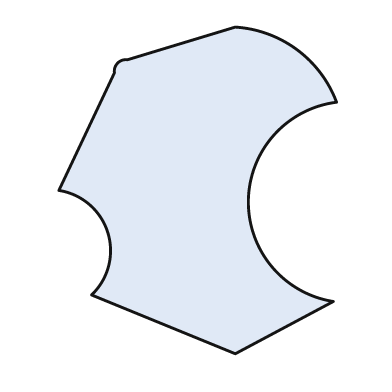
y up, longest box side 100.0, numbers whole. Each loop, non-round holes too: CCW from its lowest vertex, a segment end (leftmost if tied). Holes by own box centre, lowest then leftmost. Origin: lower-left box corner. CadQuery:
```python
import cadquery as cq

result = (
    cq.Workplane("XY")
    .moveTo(54.0, 0.0)
    .lineTo(84.0, 16.0)
    .threePointArc((58.0, 47.0), (85.0, 77.0))
    .threePointArc((73.0, 93.0), (54.0, 100.0))
    .lineTo(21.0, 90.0)
    .threePointArc((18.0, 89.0), (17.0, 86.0))
    .lineTo(0.0, 50.0)
    .threePointArc((15.0, 37.0), (10.0, 18.0))
    .close()
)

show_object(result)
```